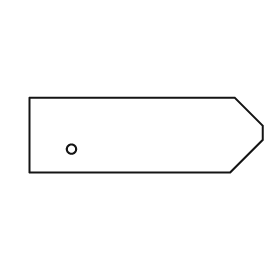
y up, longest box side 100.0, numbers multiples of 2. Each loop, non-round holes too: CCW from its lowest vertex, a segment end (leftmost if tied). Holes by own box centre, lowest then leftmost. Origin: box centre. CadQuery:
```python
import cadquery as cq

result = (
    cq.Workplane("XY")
    .moveTo(-50.0, -16.0)
    .lineTo(36.0, -16.0)
    .lineTo(50.0, -2.0)
    .lineTo(50.0, 4.0)
    .lineTo(38.0, 16.0)
    .lineTo(-50.0, 16.0)
    .close()
    .moveTo(-32.0, -6.0)
    .circle(2.0)
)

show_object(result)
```